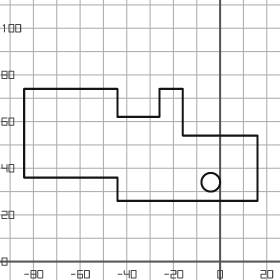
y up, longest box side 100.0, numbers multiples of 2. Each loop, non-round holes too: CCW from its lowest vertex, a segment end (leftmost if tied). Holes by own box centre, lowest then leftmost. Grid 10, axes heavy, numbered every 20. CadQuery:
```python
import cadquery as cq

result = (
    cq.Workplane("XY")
    .moveTo(-44.0, 26.0)
    .lineTo(16.0, 26.0)
    .lineTo(16.0, 54.0)
    .lineTo(-16.0, 54.0)
    .lineTo(-16.0, 74.0)
    .lineTo(-26.0, 74.0)
    .lineTo(-26.0, 62.0)
    .lineTo(-44.0, 62.0)
    .lineTo(-44.0, 74.0)
    .lineTo(-84.0, 74.0)
    .lineTo(-84.0, 36.0)
    .lineTo(-44.0, 36.0)
    .close()
    .moveTo(-4.0, 34.0)
    .circle(4.0)
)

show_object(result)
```